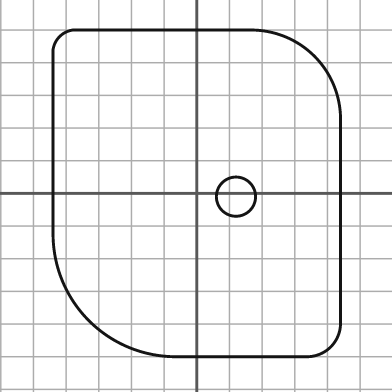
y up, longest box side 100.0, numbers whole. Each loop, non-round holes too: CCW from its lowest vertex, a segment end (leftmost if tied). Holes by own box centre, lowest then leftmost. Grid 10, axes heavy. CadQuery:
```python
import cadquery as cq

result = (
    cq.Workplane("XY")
    .moveTo(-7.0, -50.0)
    .lineTo(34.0, -50.0)
    .threePointArc((41.0, -47.0), (44.0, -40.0))
    .lineTo(44.0, 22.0)
    .threePointArc((36.0, 42.0), (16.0, 50.0))
    .lineTo(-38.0, 50.0)
    .threePointArc((-42.0, 48.0), (-44.0, 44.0))
    .lineTo(-44.0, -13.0)
    .threePointArc((-33.0, -39.0), (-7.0, -50.0))
    .close()
    .moveTo(12.0, -1.0)
    .circle(6.0)
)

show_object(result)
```